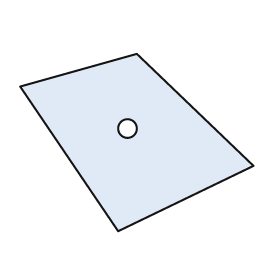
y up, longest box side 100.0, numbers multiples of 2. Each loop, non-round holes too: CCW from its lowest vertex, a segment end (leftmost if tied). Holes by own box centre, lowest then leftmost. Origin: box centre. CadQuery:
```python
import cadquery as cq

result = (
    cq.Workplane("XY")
    .moveTo(-8.0, -38.0)
    .lineTo(50.0, -10.0)
    .lineTo(0.0, 38.0)
    .lineTo(-50.0, 24.0)
    .close()
    .moveTo(-4.0, 6.0)
    .circle(4.0)
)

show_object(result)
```